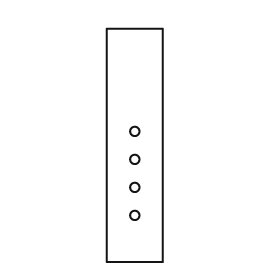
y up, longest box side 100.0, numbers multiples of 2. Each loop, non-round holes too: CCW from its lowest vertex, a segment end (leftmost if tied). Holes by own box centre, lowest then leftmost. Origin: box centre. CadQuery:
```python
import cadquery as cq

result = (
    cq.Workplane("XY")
    .moveTo(-12.0, -50.0)
    .lineTo(12.0, -50.0)
    .lineTo(12.0, 50.0)
    .lineTo(-12.0, 50.0)
    .close()
    .moveTo(0.0, -30.0)
    .circle(2.0)
    .moveTo(0.0, -18.0)
    .circle(2.0)
    .moveTo(0.0, -6.0)
    .circle(2.0)
    .moveTo(0.0, 6.0)
    .circle(2.0)
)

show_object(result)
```